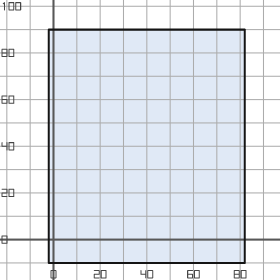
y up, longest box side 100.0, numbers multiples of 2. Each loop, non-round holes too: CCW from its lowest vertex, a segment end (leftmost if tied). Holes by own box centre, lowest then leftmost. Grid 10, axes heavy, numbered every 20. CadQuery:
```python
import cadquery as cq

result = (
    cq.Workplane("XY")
    .moveTo(-2.0, -10.0)
    .lineTo(82.0, -10.0)
    .lineTo(82.0, 90.0)
    .lineTo(-2.0, 90.0)
    .close()
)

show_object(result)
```